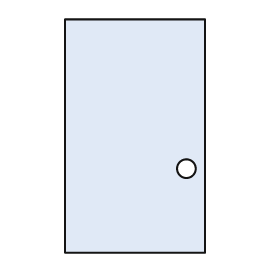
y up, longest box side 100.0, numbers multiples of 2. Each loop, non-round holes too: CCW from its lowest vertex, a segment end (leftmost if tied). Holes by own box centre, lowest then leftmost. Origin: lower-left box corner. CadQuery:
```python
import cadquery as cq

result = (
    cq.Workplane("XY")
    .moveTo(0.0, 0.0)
    .lineTo(60.0, 0.0)
    .lineTo(60.0, 100.0)
    .lineTo(0.0, 100.0)
    .close()
    .moveTo(52.0, 36.0)
    .circle(4.0)
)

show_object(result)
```